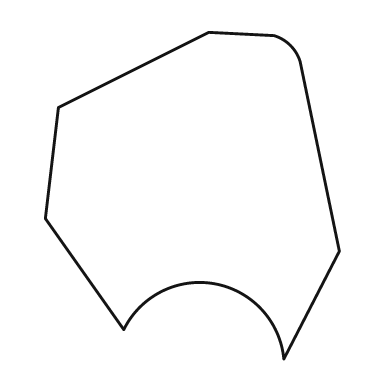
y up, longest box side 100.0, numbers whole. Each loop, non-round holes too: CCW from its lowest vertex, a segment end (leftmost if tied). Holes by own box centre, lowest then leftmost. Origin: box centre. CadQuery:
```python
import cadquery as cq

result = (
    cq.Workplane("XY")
    .moveTo(28.0, -50.0)
    .lineTo(45.0, -17.0)
    .lineTo(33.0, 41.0)
    .threePointArc((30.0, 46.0), (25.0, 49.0))
    .lineTo(5.0, 50.0)
    .lineTo(-41.0, 27.0)
    .lineTo(-45.0, -7.0)
    .lineTo(-21.0, -41.0)
    .threePointArc((7.0, -27.0), (28.0, -50.0))
    .close()
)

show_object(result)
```